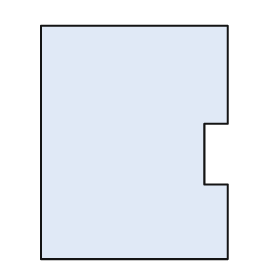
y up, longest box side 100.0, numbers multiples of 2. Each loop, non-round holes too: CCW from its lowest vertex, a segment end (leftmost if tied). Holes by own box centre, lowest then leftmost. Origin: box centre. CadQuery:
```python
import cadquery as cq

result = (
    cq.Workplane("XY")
    .moveTo(-40.0, -50.0)
    .lineTo(40.0, -50.0)
    .lineTo(40.0, -18.0)
    .lineTo(30.0, -18.0)
    .lineTo(30.0, 8.0)
    .lineTo(40.0, 8.0)
    .lineTo(40.0, 50.0)
    .lineTo(-40.0, 50.0)
    .close()
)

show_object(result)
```